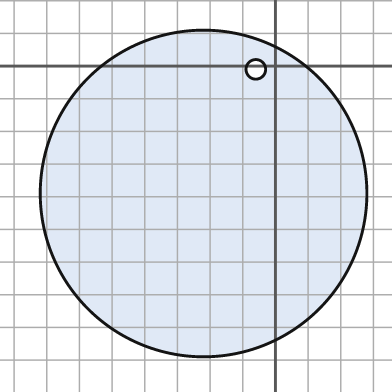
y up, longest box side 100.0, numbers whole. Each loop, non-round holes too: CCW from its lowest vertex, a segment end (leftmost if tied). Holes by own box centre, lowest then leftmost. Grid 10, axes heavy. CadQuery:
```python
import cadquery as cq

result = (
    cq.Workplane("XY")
    .moveTo(-22.0, -39.0)
    .circle(50.0)
    .moveTo(-6.0, -1.0)
    .circle(3.0)
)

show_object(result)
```